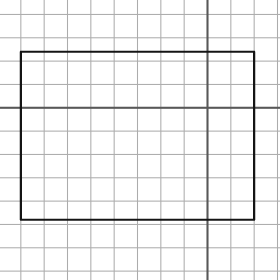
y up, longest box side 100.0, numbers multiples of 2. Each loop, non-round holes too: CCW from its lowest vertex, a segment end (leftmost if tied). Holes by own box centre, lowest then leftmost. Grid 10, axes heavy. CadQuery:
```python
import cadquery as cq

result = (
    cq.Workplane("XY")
    .moveTo(-80.0, -48.0)
    .lineTo(20.0, -48.0)
    .lineTo(20.0, 24.0)
    .lineTo(-80.0, 24.0)
    .close()
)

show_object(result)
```